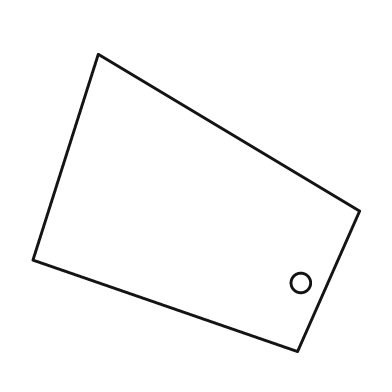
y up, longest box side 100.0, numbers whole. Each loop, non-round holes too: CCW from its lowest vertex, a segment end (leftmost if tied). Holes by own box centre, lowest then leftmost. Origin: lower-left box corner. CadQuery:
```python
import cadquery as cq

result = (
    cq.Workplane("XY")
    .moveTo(81.0, 0.0)
    .lineTo(100.0, 43.0)
    .lineTo(20.0, 91.0)
    .lineTo(0.0, 28.0)
    .close()
    .moveTo(82.0, 21.0)
    .circle(3.0)
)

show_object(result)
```